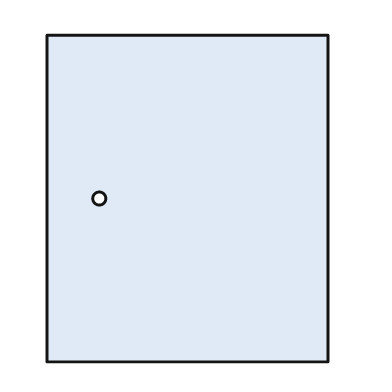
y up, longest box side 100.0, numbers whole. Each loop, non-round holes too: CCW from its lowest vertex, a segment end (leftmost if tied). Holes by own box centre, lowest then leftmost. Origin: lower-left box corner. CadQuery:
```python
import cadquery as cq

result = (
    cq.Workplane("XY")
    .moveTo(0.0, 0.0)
    .lineTo(86.0, 0.0)
    .lineTo(86.0, 100.0)
    .lineTo(0.0, 100.0)
    .close()
    .moveTo(16.0, 50.0)
    .circle(2.0)
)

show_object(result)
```